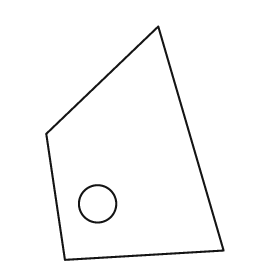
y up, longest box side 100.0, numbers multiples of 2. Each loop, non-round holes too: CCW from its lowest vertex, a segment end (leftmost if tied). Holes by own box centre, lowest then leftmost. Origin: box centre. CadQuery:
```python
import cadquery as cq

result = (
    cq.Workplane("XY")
    .moveTo(-30.0, -50.0)
    .lineTo(38.0, -46.0)
    .lineTo(10.0, 50.0)
    .lineTo(-38.0, 4.0)
    .close()
    .moveTo(-16.0, -26.0)
    .circle(8.0)
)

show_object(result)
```